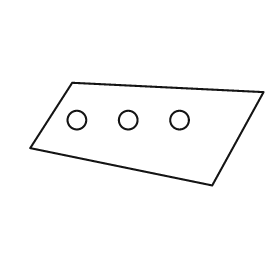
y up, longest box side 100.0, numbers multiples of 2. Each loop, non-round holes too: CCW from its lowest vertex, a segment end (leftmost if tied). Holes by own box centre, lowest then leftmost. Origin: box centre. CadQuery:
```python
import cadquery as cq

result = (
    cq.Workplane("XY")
    .moveTo(28.0, -22.0)
    .lineTo(50.0, 18.0)
    .lineTo(-32.0, 22.0)
    .lineTo(-50.0, -6.0)
    .close()
    .moveTo(-30.0, 6.0)
    .circle(4.0)
    .moveTo(-8.0, 6.0)
    .circle(4.0)
    .moveTo(14.0, 6.0)
    .circle(4.0)
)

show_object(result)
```